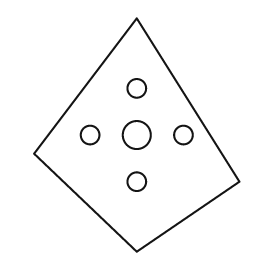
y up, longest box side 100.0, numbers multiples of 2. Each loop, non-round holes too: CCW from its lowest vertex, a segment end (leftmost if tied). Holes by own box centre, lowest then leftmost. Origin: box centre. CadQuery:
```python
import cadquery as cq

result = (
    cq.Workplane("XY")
    .moveTo(0.0, -50.0)
    .lineTo(44.0, -20.0)
    .lineTo(0.0, 50.0)
    .lineTo(-44.0, -8.0)
    .close()
    .moveTo(0.0, -20.0)
    .circle(4.0)
    .moveTo(-20.0, 0.0)
    .circle(4.0)
    .moveTo(0.0, 0.0)
    .circle(6.0)
    .moveTo(20.0, 0.0)
    .circle(4.0)
    .moveTo(0.0, 20.0)
    .circle(4.0)
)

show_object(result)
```